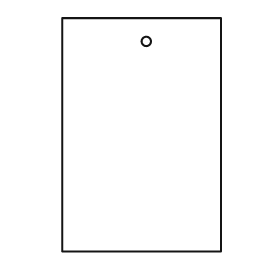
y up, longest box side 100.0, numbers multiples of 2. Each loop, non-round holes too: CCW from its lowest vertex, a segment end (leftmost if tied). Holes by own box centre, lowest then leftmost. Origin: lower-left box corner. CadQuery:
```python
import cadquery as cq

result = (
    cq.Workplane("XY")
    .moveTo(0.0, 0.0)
    .lineTo(68.0, 0.0)
    .lineTo(68.0, 100.0)
    .lineTo(0.0, 100.0)
    .close()
    .moveTo(36.0, 90.0)
    .circle(2.0)
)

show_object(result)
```